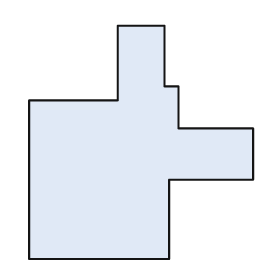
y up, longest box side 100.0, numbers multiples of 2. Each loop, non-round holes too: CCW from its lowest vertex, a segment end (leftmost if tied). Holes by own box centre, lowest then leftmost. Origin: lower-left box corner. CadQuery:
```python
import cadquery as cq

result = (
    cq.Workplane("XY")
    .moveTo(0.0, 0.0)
    .lineTo(60.0, 0.0)
    .lineTo(60.0, 34.0)
    .lineTo(96.0, 34.0)
    .lineTo(96.0, 56.0)
    .lineTo(64.0, 56.0)
    .lineTo(64.0, 74.0)
    .lineTo(58.0, 74.0)
    .lineTo(58.0, 100.0)
    .lineTo(38.0, 100.0)
    .lineTo(38.0, 68.0)
    .lineTo(0.0, 68.0)
    .close()
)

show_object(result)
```